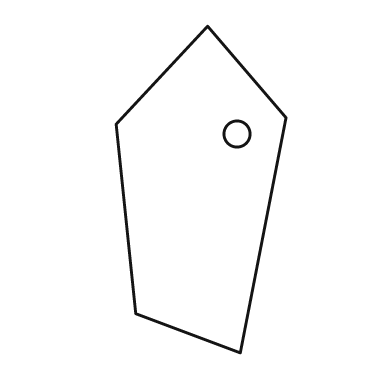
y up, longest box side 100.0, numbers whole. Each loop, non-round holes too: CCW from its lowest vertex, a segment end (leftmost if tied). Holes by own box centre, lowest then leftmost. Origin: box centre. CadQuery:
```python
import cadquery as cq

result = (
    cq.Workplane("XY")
    .moveTo(12.0, -50.0)
    .lineTo(26.0, 22.0)
    .lineTo(2.0, 50.0)
    .lineTo(-26.0, 20.0)
    .lineTo(-20.0, -38.0)
    .close()
    .moveTo(11.0, 17.0)
    .circle(4.0)
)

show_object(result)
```